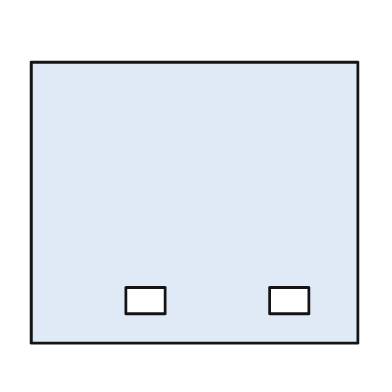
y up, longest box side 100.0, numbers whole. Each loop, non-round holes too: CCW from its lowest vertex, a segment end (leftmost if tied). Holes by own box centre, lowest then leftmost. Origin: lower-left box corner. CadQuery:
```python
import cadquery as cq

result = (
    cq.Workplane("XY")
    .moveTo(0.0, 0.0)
    .lineTo(100.0, 0.0)
    .lineTo(100.0, 86.0)
    .lineTo(0.0, 86.0)
    .close()
    .moveTo(29.0, 9.0)
    .lineTo(41.0, 9.0)
    .lineTo(41.0, 17.0)
    .lineTo(29.0, 17.0)
    .close()
    .moveTo(73.0, 9.0)
    .lineTo(85.0, 9.0)
    .lineTo(85.0, 17.0)
    .lineTo(73.0, 17.0)
    .close()
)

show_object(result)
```